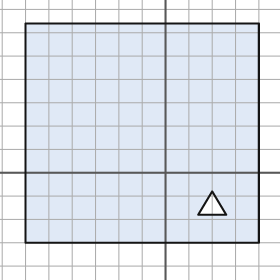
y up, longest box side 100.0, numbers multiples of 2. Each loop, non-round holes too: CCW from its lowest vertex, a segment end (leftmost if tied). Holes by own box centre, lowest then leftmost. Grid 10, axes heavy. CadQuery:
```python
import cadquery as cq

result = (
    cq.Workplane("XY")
    .moveTo(-60.0, -30.0)
    .lineTo(40.0, -30.0)
    .lineTo(40.0, 64.0)
    .lineTo(-60.0, 64.0)
    .close()
    .moveTo(14.0, -18.0)
    .lineTo(26.0, -18.0)
    .lineTo(20.0, -8.0)
    .close()
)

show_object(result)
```